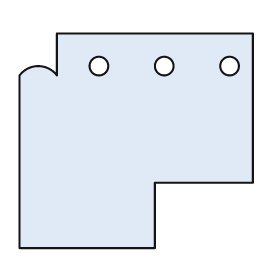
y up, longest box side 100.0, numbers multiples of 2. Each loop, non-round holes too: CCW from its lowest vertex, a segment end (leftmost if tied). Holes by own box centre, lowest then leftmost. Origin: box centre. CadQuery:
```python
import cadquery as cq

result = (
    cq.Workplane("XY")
    .moveTo(-50.0, -46.0)
    .lineTo(8.0, -46.0)
    .lineTo(8.0, -18.0)
    .lineTo(50.0, -18.0)
    .lineTo(50.0, 46.0)
    .lineTo(-34.0, 46.0)
    .lineTo(-34.0, 28.0)
    .threePointArc((-42.0, 32.0), (-50.0, 28.0))
    .close()
    .moveTo(-16.0, 32.0)
    .circle(4.0)
    .moveTo(12.0, 32.0)
    .circle(4.0)
    .moveTo(40.0, 32.0)
    .circle(4.0)
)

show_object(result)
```